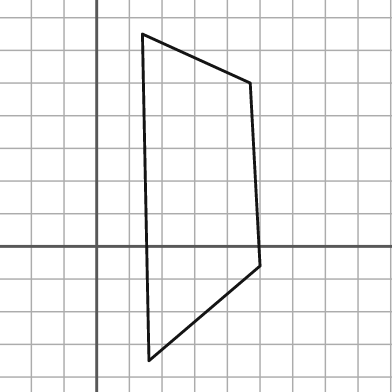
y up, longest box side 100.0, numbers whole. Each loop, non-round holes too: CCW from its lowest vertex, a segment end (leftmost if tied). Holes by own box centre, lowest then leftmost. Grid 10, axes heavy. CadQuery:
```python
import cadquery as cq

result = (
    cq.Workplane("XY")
    .moveTo(16.0, -35.0)
    .lineTo(50.0, -6.0)
    .lineTo(47.0, 50.0)
    .lineTo(14.0, 65.0)
    .close()
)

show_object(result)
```